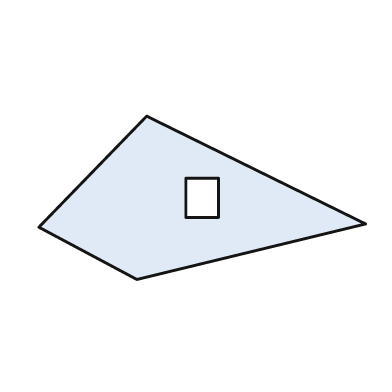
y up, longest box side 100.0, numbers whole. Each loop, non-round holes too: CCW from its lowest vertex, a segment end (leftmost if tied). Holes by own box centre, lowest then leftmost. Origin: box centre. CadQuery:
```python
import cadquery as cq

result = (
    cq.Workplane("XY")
    .moveTo(-20.0, -25.0)
    .lineTo(50.0, -8.0)
    .lineTo(-17.0, 25.0)
    .lineTo(-50.0, -9.0)
    .close()
    .moveTo(-5.0, -6.0)
    .lineTo(5.0, -6.0)
    .lineTo(5.0, 6.0)
    .lineTo(-5.0, 6.0)
    .close()
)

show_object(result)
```